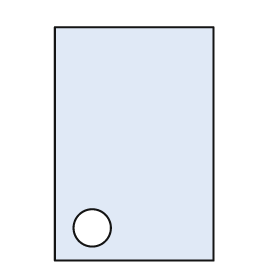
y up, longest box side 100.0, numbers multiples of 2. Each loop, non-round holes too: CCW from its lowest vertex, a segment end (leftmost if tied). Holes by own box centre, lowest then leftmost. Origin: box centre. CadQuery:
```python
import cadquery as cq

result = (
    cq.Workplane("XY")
    .moveTo(-34.0, -50.0)
    .lineTo(34.0, -50.0)
    .lineTo(34.0, 50.0)
    .lineTo(-34.0, 50.0)
    .close()
    .moveTo(-18.0, -36.0)
    .circle(8.0)
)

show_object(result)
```